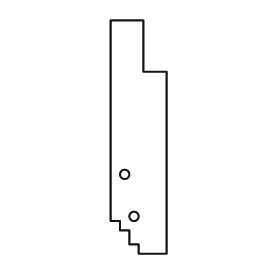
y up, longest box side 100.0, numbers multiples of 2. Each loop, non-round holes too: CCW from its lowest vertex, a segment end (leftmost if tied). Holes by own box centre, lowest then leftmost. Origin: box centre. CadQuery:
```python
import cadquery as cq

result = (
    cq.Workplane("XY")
    .moveTo(0.0, -50.0)
    .lineTo(12.0, -50.0)
    .lineTo(12.0, 28.0)
    .lineTo(2.0, 28.0)
    .lineTo(2.0, 50.0)
    .lineTo(-12.0, 50.0)
    .lineTo(-12.0, -36.0)
    .lineTo(-8.0, -36.0)
    .lineTo(-8.0, -40.0)
    .lineTo(-4.0, -40.0)
    .lineTo(-4.0, -46.0)
    .lineTo(0.0, -46.0)
    .close()
    .moveTo(-2.0, -34.0)
    .circle(2.0)
    .moveTo(-6.0, -16.0)
    .circle(2.0)
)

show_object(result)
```